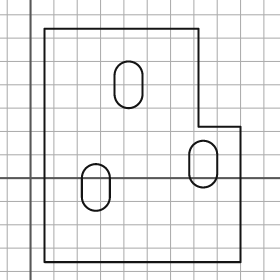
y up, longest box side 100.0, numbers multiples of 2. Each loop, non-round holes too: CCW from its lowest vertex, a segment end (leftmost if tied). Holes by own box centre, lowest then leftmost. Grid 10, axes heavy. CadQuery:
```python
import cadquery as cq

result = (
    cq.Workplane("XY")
    .moveTo(6.0, -36.0)
    .lineTo(90.0, -36.0)
    .lineTo(90.0, 22.0)
    .lineTo(72.0, 22.0)
    .lineTo(72.0, 64.0)
    .lineTo(6.0, 64.0)
    .close()
    .moveTo(22.0, -8.0)
    .threePointArc((28.0, -14.0), (34.0, -8.0))
    .lineTo(34.0, 0.0)
    .threePointArc((28.0, 6.0), (22.0, 0.0))
    .close()
    .moveTo(68.0, 2.0)
    .threePointArc((74.0, -4.0), (80.0, 2.0))
    .lineTo(80.0, 10.0)
    .threePointArc((74.0, 16.0), (68.0, 10.0))
    .close()
    .moveTo(36.0, 36.0)
    .threePointArc((42.0, 30.0), (48.0, 36.0))
    .lineTo(48.0, 44.0)
    .threePointArc((42.0, 50.0), (36.0, 44.0))
    .close()
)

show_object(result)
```